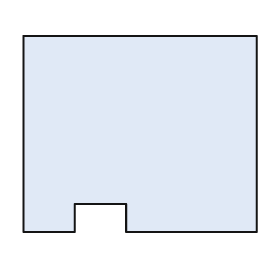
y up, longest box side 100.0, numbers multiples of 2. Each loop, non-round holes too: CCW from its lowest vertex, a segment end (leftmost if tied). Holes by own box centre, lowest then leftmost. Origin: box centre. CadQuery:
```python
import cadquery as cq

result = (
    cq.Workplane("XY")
    .moveTo(-50.0, -42.0)
    .lineTo(-28.0, -42.0)
    .lineTo(-28.0, -30.0)
    .lineTo(-6.0, -30.0)
    .lineTo(-6.0, -42.0)
    .lineTo(50.0, -42.0)
    .lineTo(50.0, 42.0)
    .lineTo(-50.0, 42.0)
    .close()
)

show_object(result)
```